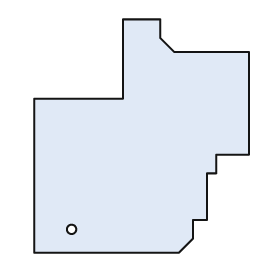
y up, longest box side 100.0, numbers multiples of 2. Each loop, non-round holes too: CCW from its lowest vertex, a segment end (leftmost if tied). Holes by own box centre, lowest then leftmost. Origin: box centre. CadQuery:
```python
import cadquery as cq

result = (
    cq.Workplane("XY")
    .moveTo(-46.0, -50.0)
    .lineTo(16.0, -50.0)
    .lineTo(22.0, -44.0)
    .lineTo(22.0, -36.0)
    .lineTo(28.0, -36.0)
    .lineTo(28.0, -16.0)
    .lineTo(32.0, -16.0)
    .lineTo(32.0, -8.0)
    .lineTo(46.0, -8.0)
    .lineTo(46.0, 36.0)
    .lineTo(14.0, 36.0)
    .lineTo(8.0, 42.0)
    .lineTo(8.0, 50.0)
    .lineTo(-8.0, 50.0)
    .lineTo(-8.0, 16.0)
    .lineTo(-46.0, 16.0)
    .close()
    .moveTo(-30.0, -40.0)
    .circle(2.0)
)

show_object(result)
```